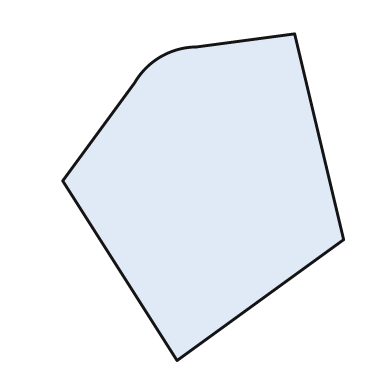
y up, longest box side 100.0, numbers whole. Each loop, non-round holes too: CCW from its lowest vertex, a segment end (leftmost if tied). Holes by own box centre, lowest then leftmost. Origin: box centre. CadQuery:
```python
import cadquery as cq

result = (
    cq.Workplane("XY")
    .moveTo(-8.0, -50.0)
    .lineTo(43.0, -13.0)
    .lineTo(28.0, 50.0)
    .lineTo(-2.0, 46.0)
    .threePointArc((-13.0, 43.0), (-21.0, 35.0))
    .lineTo(-43.0, 5.0)
    .close()
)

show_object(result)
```